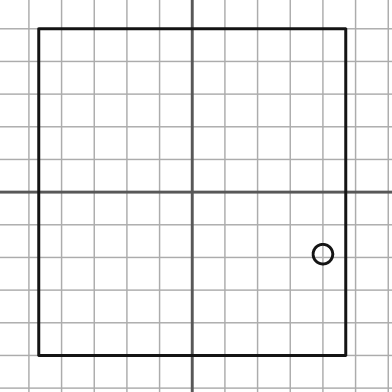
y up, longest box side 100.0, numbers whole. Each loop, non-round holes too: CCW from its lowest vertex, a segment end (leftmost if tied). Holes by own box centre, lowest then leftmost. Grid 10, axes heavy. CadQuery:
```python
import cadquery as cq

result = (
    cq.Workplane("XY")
    .moveTo(-47.0, -50.0)
    .lineTo(47.0, -50.0)
    .lineTo(47.0, 50.0)
    .lineTo(-47.0, 50.0)
    .close()
    .moveTo(40.0, -19.0)
    .circle(3.0)
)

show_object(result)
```